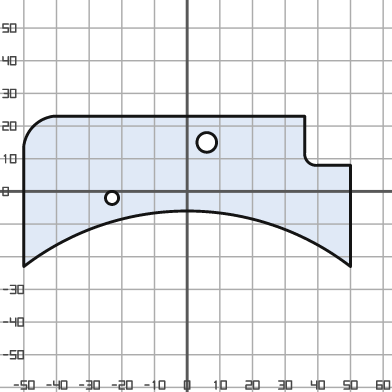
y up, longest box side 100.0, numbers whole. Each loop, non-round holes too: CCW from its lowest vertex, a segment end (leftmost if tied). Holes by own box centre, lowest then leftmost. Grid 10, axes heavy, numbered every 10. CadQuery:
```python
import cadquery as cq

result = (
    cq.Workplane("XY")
    .moveTo(-50.0, -23.0)
    .threePointArc((0.0, -6.0), (50.0, -23.0))
    .lineTo(50.0, 8.0)
    .lineTo(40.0, 8.0)
    .threePointArc((37.0, 9.0), (36.0, 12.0))
    .lineTo(36.0, 23.0)
    .lineTo(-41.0, 23.0)
    .threePointArc((-47.0, 20.0), (-50.0, 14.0))
    .close()
    .moveTo(-23.0, -2.0)
    .circle(2.0)
    .moveTo(6.0, 15.0)
    .circle(3.0)
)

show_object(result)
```